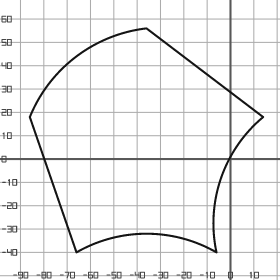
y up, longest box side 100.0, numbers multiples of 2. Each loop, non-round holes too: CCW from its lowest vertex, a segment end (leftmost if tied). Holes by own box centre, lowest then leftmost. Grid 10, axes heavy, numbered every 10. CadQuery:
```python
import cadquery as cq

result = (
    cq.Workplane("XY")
    .moveTo(-66.0, -40.0)
    .threePointArc((-36.0, -32.0), (-6.0, -40.0))
    .threePointArc((-4.0, -8.0), (14.0, 18.0))
    .lineTo(-36.0, 56.0)
    .threePointArc((-66.0, 44.0), (-86.0, 18.0))
    .close()
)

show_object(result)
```